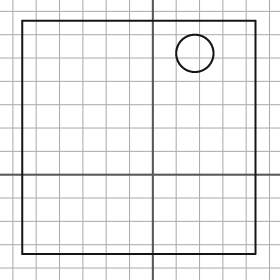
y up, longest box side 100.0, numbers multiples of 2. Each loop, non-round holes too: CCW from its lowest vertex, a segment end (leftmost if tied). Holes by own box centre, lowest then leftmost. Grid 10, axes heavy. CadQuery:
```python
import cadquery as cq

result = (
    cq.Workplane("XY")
    .moveTo(-56.0, -34.0)
    .lineTo(44.0, -34.0)
    .lineTo(44.0, 66.0)
    .lineTo(-56.0, 66.0)
    .close()
    .moveTo(18.0, 52.0)
    .circle(8.0)
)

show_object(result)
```